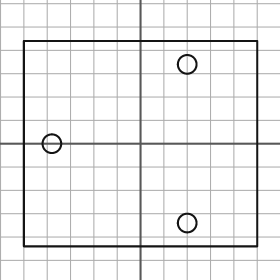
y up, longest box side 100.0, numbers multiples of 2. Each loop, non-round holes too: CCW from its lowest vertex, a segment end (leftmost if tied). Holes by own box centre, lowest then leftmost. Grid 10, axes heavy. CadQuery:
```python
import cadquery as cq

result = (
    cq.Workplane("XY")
    .moveTo(-50.0, -44.0)
    .lineTo(50.0, -44.0)
    .lineTo(50.0, 44.0)
    .lineTo(-50.0, 44.0)
    .close()
    .moveTo(20.0, -34.0)
    .circle(4.0)
    .moveTo(-38.0, 0.0)
    .circle(4.0)
    .moveTo(20.0, 34.0)
    .circle(4.0)
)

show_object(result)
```